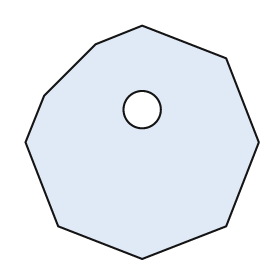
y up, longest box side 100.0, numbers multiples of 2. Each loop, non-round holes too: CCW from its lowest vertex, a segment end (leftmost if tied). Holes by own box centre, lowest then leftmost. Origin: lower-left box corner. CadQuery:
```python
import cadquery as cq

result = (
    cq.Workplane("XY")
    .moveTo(50.0, 0.0)
    .lineTo(86.0, 14.0)
    .lineTo(100.0, 50.0)
    .lineTo(86.0, 86.0)
    .lineTo(50.0, 100.0)
    .lineTo(30.0, 92.0)
    .lineTo(8.0, 70.0)
    .lineTo(0.0, 50.0)
    .lineTo(14.0, 14.0)
    .close()
    .moveTo(50.0, 64.0)
    .circle(8.0)
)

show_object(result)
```